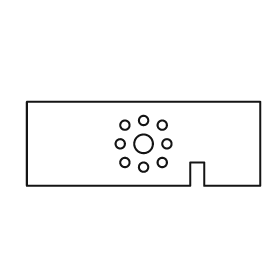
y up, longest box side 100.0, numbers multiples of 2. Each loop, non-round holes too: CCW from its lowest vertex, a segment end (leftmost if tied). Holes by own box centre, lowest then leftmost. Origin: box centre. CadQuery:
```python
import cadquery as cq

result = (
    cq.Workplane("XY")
    .moveTo(-50.0, -18.0)
    .lineTo(20.0, -18.0)
    .lineTo(20.0, -8.0)
    .lineTo(26.0, -8.0)
    .lineTo(26.0, -18.0)
    .lineTo(50.0, -18.0)
    .lineTo(50.0, 18.0)
    .lineTo(-50.0, 18.0)
    .close()
    .moveTo(0.0, -10.0)
    .circle(2.0)
    .moveTo(-8.0, -8.0)
    .circle(2.0)
    .moveTo(8.0, -8.0)
    .circle(2.0)
    .moveTo(-10.0, 0.0)
    .circle(2.0)
    .moveTo(0.0, 0.0)
    .circle(4.0)
    .moveTo(10.0, 0.0)
    .circle(2.0)
    .moveTo(-8.0, 8.0)
    .circle(2.0)
    .moveTo(8.0, 8.0)
    .circle(2.0)
    .moveTo(0.0, 10.0)
    .circle(2.0)
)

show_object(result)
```